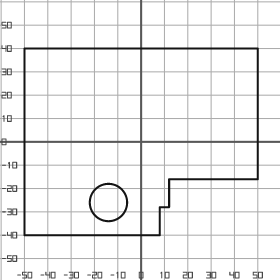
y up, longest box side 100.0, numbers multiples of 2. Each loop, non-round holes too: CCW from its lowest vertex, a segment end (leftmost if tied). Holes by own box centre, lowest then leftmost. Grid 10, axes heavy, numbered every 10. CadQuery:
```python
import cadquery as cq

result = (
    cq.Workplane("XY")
    .moveTo(-50.0, -40.0)
    .lineTo(8.0, -40.0)
    .lineTo(8.0, -28.0)
    .lineTo(12.0, -28.0)
    .lineTo(12.0, -16.0)
    .lineTo(50.0, -16.0)
    .lineTo(50.0, 40.0)
    .lineTo(-50.0, 40.0)
    .close()
    .moveTo(-14.0, -26.0)
    .circle(8.0)
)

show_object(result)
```